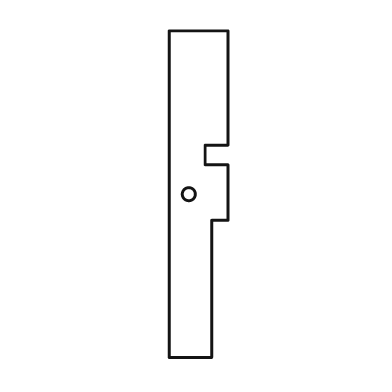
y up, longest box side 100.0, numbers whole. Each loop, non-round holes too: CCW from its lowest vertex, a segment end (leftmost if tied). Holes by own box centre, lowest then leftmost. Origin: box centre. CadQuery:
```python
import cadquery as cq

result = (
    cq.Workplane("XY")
    .moveTo(-9.0, -50.0)
    .lineTo(4.0, -50.0)
    .lineTo(4.0, -8.0)
    .lineTo(9.0, -8.0)
    .lineTo(9.0, 9.0)
    .lineTo(2.0, 9.0)
    .lineTo(2.0, 15.0)
    .lineTo(9.0, 15.0)
    .lineTo(9.0, 50.0)
    .lineTo(-9.0, 50.0)
    .close()
    .moveTo(-3.0, 0.0)
    .circle(2.0)
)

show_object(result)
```